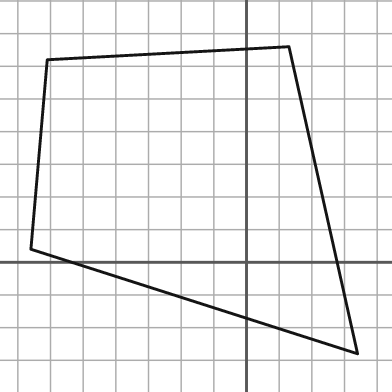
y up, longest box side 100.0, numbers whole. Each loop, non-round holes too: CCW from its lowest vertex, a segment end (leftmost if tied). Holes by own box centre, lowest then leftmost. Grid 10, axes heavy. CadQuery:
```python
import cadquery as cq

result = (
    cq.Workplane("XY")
    .moveTo(34.0, -28.0)
    .lineTo(13.0, 66.0)
    .lineTo(-61.0, 62.0)
    .lineTo(-66.0, 4.0)
    .close()
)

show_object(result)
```